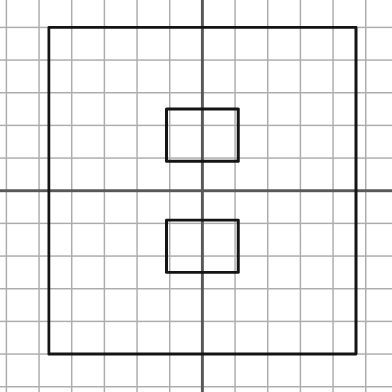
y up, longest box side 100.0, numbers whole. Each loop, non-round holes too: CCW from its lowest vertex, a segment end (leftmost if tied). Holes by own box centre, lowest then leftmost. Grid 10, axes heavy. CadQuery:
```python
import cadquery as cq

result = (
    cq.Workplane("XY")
    .moveTo(-47.0, -50.0)
    .lineTo(47.0, -50.0)
    .lineTo(47.0, 50.0)
    .lineTo(-47.0, 50.0)
    .close()
    .moveTo(-11.0, -25.0)
    .lineTo(11.0, -25.0)
    .lineTo(11.0, -9.0)
    .lineTo(-11.0, -9.0)
    .close()
    .moveTo(-11.0, 9.0)
    .lineTo(11.0, 9.0)
    .lineTo(11.0, 25.0)
    .lineTo(-11.0, 25.0)
    .close()
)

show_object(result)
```